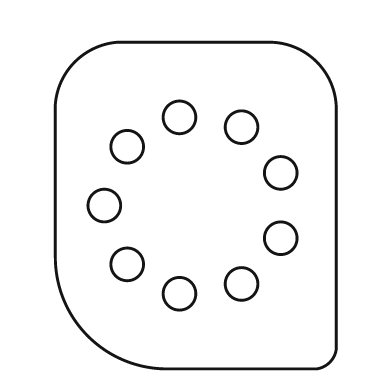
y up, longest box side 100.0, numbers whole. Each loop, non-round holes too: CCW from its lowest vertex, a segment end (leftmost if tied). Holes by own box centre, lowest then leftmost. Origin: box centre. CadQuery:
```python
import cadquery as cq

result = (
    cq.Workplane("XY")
    .moveTo(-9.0, -50.0)
    .lineTo(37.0, -50.0)
    .threePointArc((41.0, -48.0), (43.0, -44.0))
    .lineTo(43.0, 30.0)
    .threePointArc((37.0, 44.0), (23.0, 50.0))
    .lineTo(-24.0, 50.0)
    .threePointArc((-37.0, 44.0), (-43.0, 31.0))
    .lineTo(-43.0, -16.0)
    .threePointArc((-33.0, -40.0), (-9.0, -50.0))
    .close()
    .moveTo(-5.0, -27.0)
    .circle(5.0)
    .moveTo(14.0, -24.0)
    .circle(5.0)
    .moveTo(-21.0, -18.0)
    .circle(5.0)
    .moveTo(26.0, -10.0)
    .circle(5.0)
    .moveTo(-28.0, 0.0)
    .circle(5.0)
    .moveTo(26.0, 10.0)
    .circle(5.0)
    .moveTo(-21.0, 18.0)
    .circle(5.0)
    .moveTo(14.0, 24.0)
    .circle(5.0)
    .moveTo(-5.0, 27.0)
    .circle(5.0)
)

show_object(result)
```